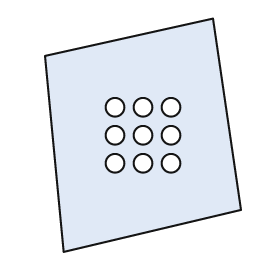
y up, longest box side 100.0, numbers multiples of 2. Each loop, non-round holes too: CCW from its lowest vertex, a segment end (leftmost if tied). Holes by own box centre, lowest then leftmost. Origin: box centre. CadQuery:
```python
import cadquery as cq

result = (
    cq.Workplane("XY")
    .moveTo(-34.0, -50.0)
    .lineTo(42.0, -32.0)
    .lineTo(30.0, 50.0)
    .lineTo(-42.0, 34.0)
    .close()
    .moveTo(-12.0, -12.0)
    .circle(4.0)
    .moveTo(0.0, -12.0)
    .circle(4.0)
    .moveTo(12.0, -12.0)
    .circle(4.0)
    .moveTo(-12.0, 0.0)
    .circle(4.0)
    .moveTo(0.0, 0.0)
    .circle(4.0)
    .moveTo(12.0, 0.0)
    .circle(4.0)
    .moveTo(-12.0, 12.0)
    .circle(4.0)
    .moveTo(0.0, 12.0)
    .circle(4.0)
    .moveTo(12.0, 12.0)
    .circle(4.0)
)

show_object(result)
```